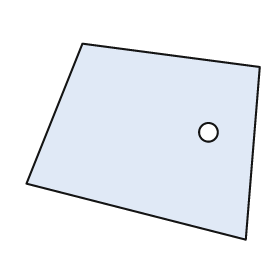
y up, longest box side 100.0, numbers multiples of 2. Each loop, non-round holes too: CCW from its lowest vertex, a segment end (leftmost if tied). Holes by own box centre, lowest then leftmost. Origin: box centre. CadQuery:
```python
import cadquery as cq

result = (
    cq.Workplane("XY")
    .moveTo(44.0, -42.0)
    .lineTo(50.0, 32.0)
    .lineTo(-26.0, 42.0)
    .lineTo(-50.0, -18.0)
    .close()
    .moveTo(28.0, 4.0)
    .circle(4.0)
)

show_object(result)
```